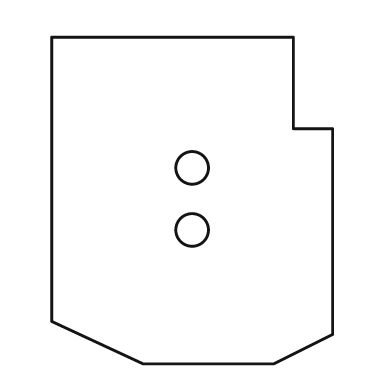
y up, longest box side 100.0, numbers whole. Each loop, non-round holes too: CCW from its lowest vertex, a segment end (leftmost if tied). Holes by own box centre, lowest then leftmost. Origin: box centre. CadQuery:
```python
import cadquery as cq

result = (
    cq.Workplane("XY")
    .moveTo(-15.0, -50.0)
    .lineTo(25.0, -50.0)
    .lineTo(43.0, -41.0)
    .lineTo(43.0, 22.0)
    .lineTo(31.0, 22.0)
    .lineTo(31.0, 50.0)
    .lineTo(-43.0, 50.0)
    .lineTo(-43.0, -37.0)
    .close()
    .moveTo(0.0, -9.0)
    .circle(5.0)
    .moveTo(0.0, 10.0)
    .circle(5.0)
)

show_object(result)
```